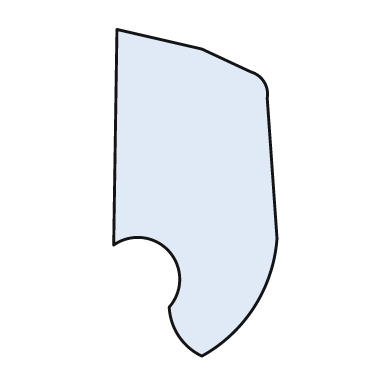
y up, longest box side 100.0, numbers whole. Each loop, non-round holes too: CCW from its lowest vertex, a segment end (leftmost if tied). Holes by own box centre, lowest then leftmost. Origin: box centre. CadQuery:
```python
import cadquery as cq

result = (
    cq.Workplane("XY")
    .moveTo(2.0, -50.0)
    .threePointArc((18.0, -35.0), (25.0, -14.0))
    .lineTo(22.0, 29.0)
    .threePointArc((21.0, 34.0), (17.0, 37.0))
    .lineTo(2.0, 44.0)
    .lineTo(-24.0, 50.0)
    .lineTo(-25.0, -16.0)
    .threePointArc((-8.0, -18.0), (-8.0, -35.0))
    .threePointArc((-5.0, -44.0), (2.0, -50.0))
    .close()
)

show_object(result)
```